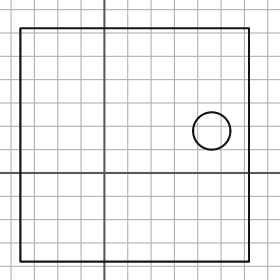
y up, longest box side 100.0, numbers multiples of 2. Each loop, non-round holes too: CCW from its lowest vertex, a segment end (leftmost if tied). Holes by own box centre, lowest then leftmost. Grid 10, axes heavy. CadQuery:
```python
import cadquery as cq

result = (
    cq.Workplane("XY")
    .moveTo(-36.0, -38.0)
    .lineTo(62.0, -38.0)
    .lineTo(62.0, 62.0)
    .lineTo(-36.0, 62.0)
    .close()
    .moveTo(46.0, 18.0)
    .circle(8.0)
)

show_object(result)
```